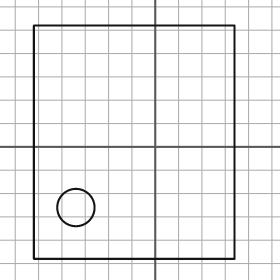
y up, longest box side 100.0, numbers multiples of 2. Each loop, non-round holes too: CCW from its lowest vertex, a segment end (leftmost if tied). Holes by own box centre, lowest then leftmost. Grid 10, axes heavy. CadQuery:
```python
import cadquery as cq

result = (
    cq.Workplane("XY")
    .moveTo(-52.0, -48.0)
    .lineTo(34.0, -48.0)
    .lineTo(34.0, 52.0)
    .lineTo(-52.0, 52.0)
    .close()
    .moveTo(-34.0, -26.0)
    .circle(8.0)
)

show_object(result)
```